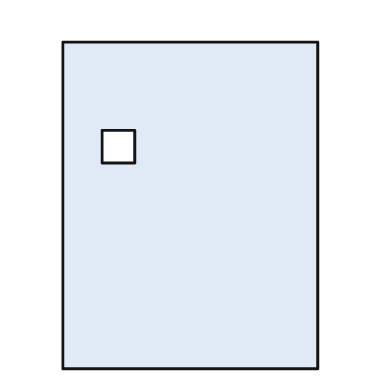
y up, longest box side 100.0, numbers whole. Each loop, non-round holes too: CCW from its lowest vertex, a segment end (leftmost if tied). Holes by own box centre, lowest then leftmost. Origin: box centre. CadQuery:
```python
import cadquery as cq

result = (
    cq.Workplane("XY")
    .moveTo(-39.0, -50.0)
    .lineTo(39.0, -50.0)
    .lineTo(39.0, 50.0)
    .lineTo(-39.0, 50.0)
    .close()
    .moveTo(-27.0, 13.0)
    .lineTo(-17.0, 13.0)
    .lineTo(-17.0, 23.0)
    .lineTo(-27.0, 23.0)
    .close()
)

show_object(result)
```